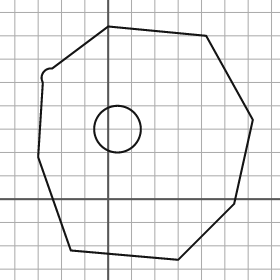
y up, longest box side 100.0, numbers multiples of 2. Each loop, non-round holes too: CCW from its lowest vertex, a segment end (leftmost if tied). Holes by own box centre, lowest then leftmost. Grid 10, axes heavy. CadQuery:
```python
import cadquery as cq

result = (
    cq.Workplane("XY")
    .moveTo(30.0, -26.0)
    .lineTo(54.0, -2.0)
    .lineTo(62.0, 34.0)
    .lineTo(42.0, 70.0)
    .lineTo(0.0, 74.0)
    .lineTo(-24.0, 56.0)
    .threePointArc((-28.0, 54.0), (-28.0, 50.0))
    .lineTo(-30.0, 18.0)
    .lineTo(-16.0, -22.0)
    .close()
    .moveTo(4.0, 30.0)
    .circle(10.0)
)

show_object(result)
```